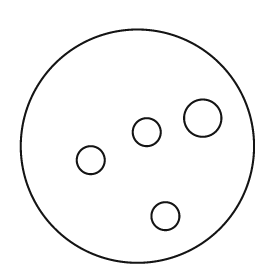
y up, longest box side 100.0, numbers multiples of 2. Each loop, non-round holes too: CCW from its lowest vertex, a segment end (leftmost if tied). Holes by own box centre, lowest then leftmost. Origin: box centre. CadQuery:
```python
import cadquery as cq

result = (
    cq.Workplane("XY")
    .moveTo(0.0, 0.0)
    .circle(50.0)
    .moveTo(12.0, -30.0)
    .circle(6.0)
    .moveTo(-20.0, -6.0)
    .circle(6.0)
    .moveTo(4.0, 6.0)
    .circle(6.0)
    .moveTo(28.0, 12.0)
    .circle(8.0)
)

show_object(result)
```